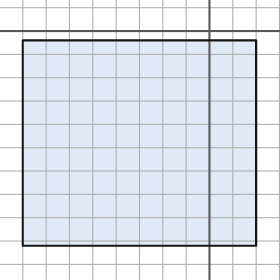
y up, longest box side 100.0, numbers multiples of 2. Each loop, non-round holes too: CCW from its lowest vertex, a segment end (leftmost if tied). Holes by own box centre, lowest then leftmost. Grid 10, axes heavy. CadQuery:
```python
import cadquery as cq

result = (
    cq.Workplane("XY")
    .moveTo(-80.0, -92.0)
    .lineTo(20.0, -92.0)
    .lineTo(20.0, -4.0)
    .lineTo(-80.0, -4.0)
    .close()
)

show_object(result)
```